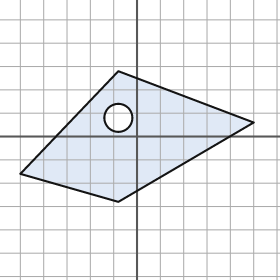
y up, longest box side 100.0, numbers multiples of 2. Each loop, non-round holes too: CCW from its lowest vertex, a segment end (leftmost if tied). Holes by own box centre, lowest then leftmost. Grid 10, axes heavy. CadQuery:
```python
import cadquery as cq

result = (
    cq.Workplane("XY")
    .moveTo(-8.0, -28.0)
    .lineTo(50.0, 6.0)
    .lineTo(-8.0, 28.0)
    .lineTo(-50.0, -16.0)
    .close()
    .moveTo(-8.0, 8.0)
    .circle(6.0)
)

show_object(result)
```